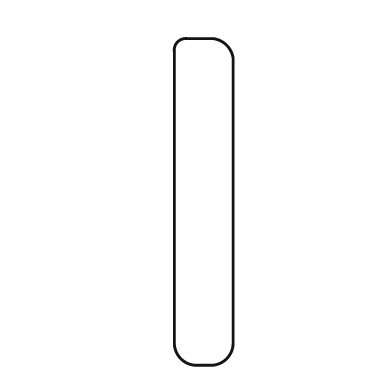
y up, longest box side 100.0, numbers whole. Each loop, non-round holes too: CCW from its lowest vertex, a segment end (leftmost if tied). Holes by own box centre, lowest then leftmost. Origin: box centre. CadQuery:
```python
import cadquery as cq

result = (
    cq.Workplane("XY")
    .moveTo(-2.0, -50.0)
    .lineTo(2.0, -50.0)
    .threePointArc((7.0, -48.0), (9.0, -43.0))
    .lineTo(9.0, 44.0)
    .threePointArc((7.0, 48.0), (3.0, 50.0))
    .lineTo(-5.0, 50.0)
    .threePointArc((-8.0, 49.0), (-9.0, 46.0))
    .lineTo(-9.0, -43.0)
    .threePointArc((-7.0, -48.0), (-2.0, -50.0))
    .close()
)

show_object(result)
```